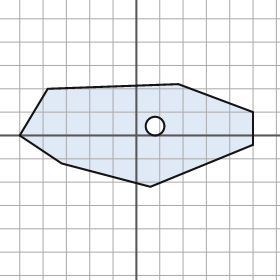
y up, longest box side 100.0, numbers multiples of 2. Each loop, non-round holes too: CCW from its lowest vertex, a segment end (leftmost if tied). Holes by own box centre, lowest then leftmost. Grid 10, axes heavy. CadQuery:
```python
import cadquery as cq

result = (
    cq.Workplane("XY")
    .moveTo(6.0, -22.0)
    .lineTo(50.0, -4.0)
    .lineTo(50.0, 10.0)
    .lineTo(18.0, 22.0)
    .lineTo(-38.0, 20.0)
    .lineTo(-50.0, 0.0)
    .lineTo(-32.0, -12.0)
    .close()
    .moveTo(8.0, 4.0)
    .circle(4.0)
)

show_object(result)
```